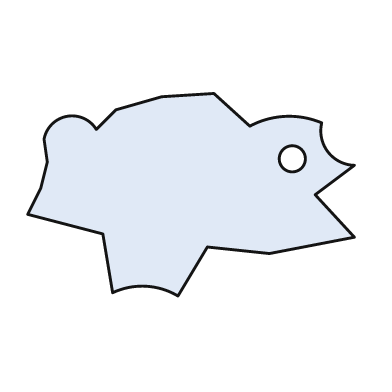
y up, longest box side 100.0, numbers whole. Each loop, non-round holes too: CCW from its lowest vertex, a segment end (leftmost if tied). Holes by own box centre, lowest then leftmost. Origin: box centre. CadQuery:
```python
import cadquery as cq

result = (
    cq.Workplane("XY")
    .moveTo(-4.0, -31.0)
    .lineTo(5.0, -16.0)
    .lineTo(24.0, -18.0)
    .lineTo(50.0, -13.0)
    .lineTo(38.0, 0.0)
    .lineTo(50.0, 9.0)
    .threePointArc((42.0, 13.0), (40.0, 22.0))
    .threePointArc((29.0, 24.0), (18.0, 21.0))
    .lineTo(7.0, 31.0)
    .lineTo(-9.0, 30.0)
    .lineTo(-23.0, 26.0)
    .lineTo(-29.0, 20.0)
    .threePointArc((-38.0, 24.0), (-45.0, 17.0))
    .lineTo(-44.0, 10.0)
    .lineTo(-46.0, 2.0)
    .lineTo(-50.0, -6.0)
    .lineTo(-27.0, -12.0)
    .lineTo(-24.0, -30.0)
    .threePointArc((-14.0, -28.0), (-4.0, -31.0))
    .close()
    .moveTo(31.0, 11.0)
    .circle(4.0)
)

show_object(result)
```